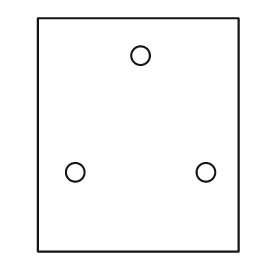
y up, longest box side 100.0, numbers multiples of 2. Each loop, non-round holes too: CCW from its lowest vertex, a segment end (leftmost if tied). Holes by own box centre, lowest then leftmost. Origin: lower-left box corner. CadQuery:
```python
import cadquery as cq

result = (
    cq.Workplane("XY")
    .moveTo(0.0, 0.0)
    .lineTo(86.0, 0.0)
    .lineTo(86.0, 100.0)
    .lineTo(0.0, 100.0)
    .close()
    .moveTo(16.0, 34.0)
    .circle(4.0)
    .moveTo(72.0, 34.0)
    .circle(4.0)
    .moveTo(44.0, 84.0)
    .circle(4.0)
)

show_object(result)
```